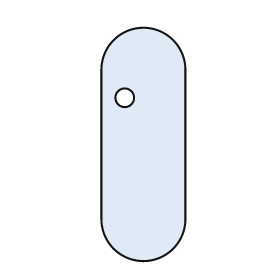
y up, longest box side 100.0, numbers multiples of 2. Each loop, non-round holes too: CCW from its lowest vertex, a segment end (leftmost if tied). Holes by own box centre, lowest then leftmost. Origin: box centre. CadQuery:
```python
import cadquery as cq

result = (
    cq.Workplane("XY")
    .moveTo(-18.0, -32.0)
    .threePointArc((0.0, -50.0), (18.0, -32.0))
    .lineTo(18.0, 32.0)
    .threePointArc((0.0, 50.0), (-18.0, 32.0))
    .close()
    .moveTo(-8.0, 20.0)
    .circle(4.0)
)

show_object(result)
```